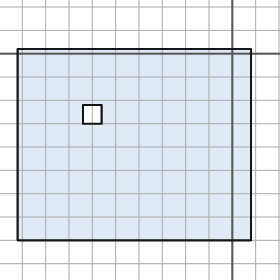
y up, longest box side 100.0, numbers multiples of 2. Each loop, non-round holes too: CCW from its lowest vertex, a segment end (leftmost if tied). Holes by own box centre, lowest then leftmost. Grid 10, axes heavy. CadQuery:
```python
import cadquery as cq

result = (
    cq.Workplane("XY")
    .moveTo(-92.0, -80.0)
    .lineTo(8.0, -80.0)
    .lineTo(8.0, 2.0)
    .lineTo(-92.0, 2.0)
    .close()
    .moveTo(-64.0, -30.0)
    .lineTo(-56.0, -30.0)
    .lineTo(-56.0, -22.0)
    .lineTo(-64.0, -22.0)
    .close()
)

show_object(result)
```